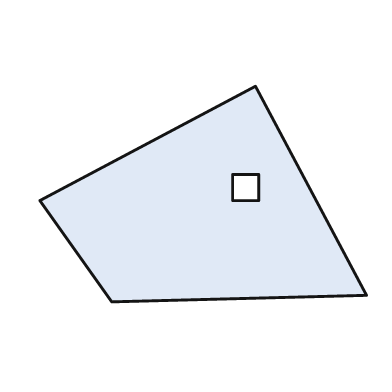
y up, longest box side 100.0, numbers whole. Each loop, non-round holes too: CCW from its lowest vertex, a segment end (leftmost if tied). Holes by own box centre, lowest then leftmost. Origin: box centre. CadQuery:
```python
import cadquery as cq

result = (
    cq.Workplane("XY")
    .moveTo(-28.0, -33.0)
    .lineTo(50.0, -31.0)
    .lineTo(16.0, 33.0)
    .lineTo(-50.0, -2.0)
    .close()
    .moveTo(9.0, -2.0)
    .lineTo(17.0, -2.0)
    .lineTo(17.0, 6.0)
    .lineTo(9.0, 6.0)
    .close()
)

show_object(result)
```